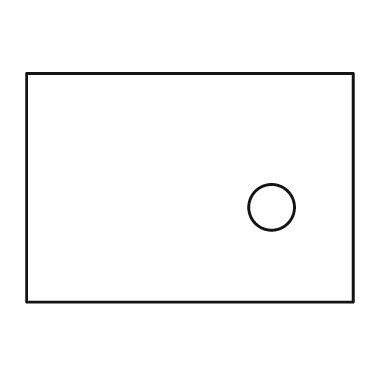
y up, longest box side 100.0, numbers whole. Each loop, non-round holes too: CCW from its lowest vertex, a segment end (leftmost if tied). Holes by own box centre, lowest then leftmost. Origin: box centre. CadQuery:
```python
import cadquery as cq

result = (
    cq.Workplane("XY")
    .moveTo(-50.0, -35.0)
    .lineTo(50.0, -35.0)
    .lineTo(50.0, 35.0)
    .lineTo(-50.0, 35.0)
    .close()
    .moveTo(25.0, -6.0)
    .circle(7.0)
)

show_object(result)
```